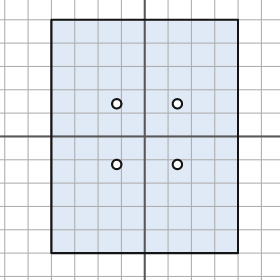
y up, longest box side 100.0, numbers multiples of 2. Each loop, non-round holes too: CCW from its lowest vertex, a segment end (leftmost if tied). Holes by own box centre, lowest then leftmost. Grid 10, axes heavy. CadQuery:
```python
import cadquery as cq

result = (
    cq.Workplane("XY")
    .moveTo(-40.0, -50.0)
    .lineTo(40.0, -50.0)
    .lineTo(40.0, 50.0)
    .lineTo(-40.0, 50.0)
    .close()
    .moveTo(-12.0, -12.0)
    .circle(2.0)
    .moveTo(14.0, -12.0)
    .circle(2.0)
    .moveTo(-12.0, 14.0)
    .circle(2.0)
    .moveTo(14.0, 14.0)
    .circle(2.0)
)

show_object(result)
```